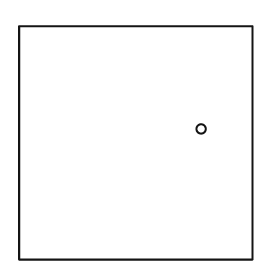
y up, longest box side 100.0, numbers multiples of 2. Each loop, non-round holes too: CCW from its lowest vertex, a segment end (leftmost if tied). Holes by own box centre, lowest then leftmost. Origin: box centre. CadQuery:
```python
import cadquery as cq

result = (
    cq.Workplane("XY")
    .moveTo(-50.0, -50.0)
    .lineTo(50.0, -50.0)
    .lineTo(50.0, 50.0)
    .lineTo(-50.0, 50.0)
    .close()
    .moveTo(28.0, 6.0)
    .circle(2.0)
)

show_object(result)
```